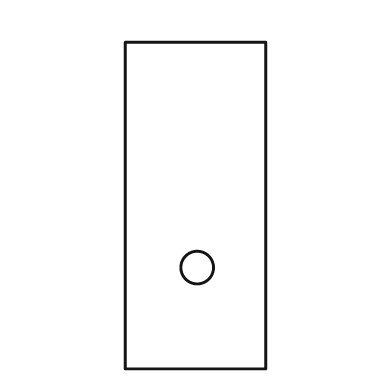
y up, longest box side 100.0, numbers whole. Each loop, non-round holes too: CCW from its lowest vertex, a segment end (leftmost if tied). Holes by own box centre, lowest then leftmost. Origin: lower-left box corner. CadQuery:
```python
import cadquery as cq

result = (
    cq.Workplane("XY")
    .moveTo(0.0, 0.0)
    .lineTo(43.0, 0.0)
    .lineTo(43.0, 100.0)
    .lineTo(0.0, 100.0)
    .close()
    .moveTo(22.0, 31.0)
    .circle(5.0)
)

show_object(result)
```